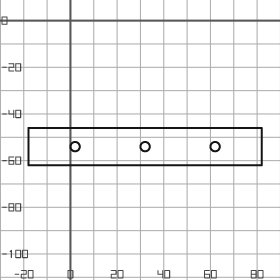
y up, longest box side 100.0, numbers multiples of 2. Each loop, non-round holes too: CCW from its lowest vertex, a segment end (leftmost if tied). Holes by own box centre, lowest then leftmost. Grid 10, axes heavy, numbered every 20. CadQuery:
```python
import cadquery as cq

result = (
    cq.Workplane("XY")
    .moveTo(-18.0, -62.0)
    .lineTo(82.0, -62.0)
    .lineTo(82.0, -46.0)
    .lineTo(-18.0, -46.0)
    .close()
    .moveTo(2.0, -54.0)
    .circle(2.0)
    .moveTo(32.0, -54.0)
    .circle(2.0)
    .moveTo(62.0, -54.0)
    .circle(2.0)
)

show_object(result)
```